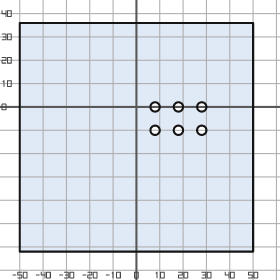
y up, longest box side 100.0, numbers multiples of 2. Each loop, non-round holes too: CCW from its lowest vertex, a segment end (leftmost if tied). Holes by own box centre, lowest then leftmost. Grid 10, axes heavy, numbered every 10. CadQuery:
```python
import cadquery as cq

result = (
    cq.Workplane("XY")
    .moveTo(-50.0, -62.0)
    .lineTo(50.0, -62.0)
    .lineTo(50.0, 36.0)
    .lineTo(-50.0, 36.0)
    .close()
    .moveTo(8.0, -10.0)
    .circle(2.0)
    .moveTo(18.0, -10.0)
    .circle(2.0)
    .moveTo(28.0, -10.0)
    .circle(2.0)
    .moveTo(8.0, 0.0)
    .circle(2.0)
    .moveTo(18.0, 0.0)
    .circle(2.0)
    .moveTo(28.0, 0.0)
    .circle(2.0)
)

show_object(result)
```